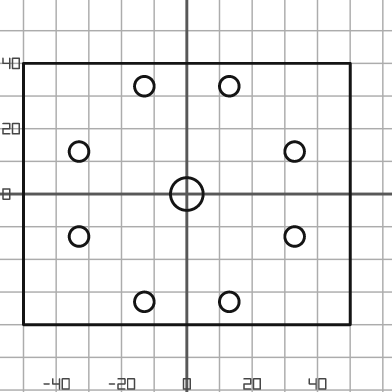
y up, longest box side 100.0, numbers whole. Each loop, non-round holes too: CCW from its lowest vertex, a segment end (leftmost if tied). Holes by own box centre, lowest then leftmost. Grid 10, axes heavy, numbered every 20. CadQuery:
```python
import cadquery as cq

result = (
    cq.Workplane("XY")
    .moveTo(-50.0, -40.0)
    .lineTo(50.0, -40.0)
    .lineTo(50.0, 40.0)
    .lineTo(-50.0, 40.0)
    .close()
    .moveTo(-13.0, -33.0)
    .circle(3.0)
    .moveTo(13.0, -33.0)
    .circle(3.0)
    .moveTo(-33.0, -13.0)
    .circle(3.0)
    .moveTo(33.0, -13.0)
    .circle(3.0)
    .moveTo(0.0, 0.0)
    .circle(5.0)
    .moveTo(-33.0, 13.0)
    .circle(3.0)
    .moveTo(33.0, 13.0)
    .circle(3.0)
    .moveTo(-13.0, 33.0)
    .circle(3.0)
    .moveTo(13.0, 33.0)
    .circle(3.0)
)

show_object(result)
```